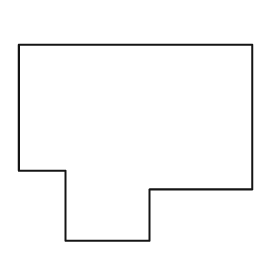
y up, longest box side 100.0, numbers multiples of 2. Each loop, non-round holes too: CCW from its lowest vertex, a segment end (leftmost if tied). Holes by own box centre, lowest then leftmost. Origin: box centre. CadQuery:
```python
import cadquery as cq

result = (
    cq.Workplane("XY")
    .moveTo(-30.0, -42.0)
    .lineTo(6.0, -42.0)
    .lineTo(6.0, -20.0)
    .lineTo(50.0, -20.0)
    .lineTo(50.0, 42.0)
    .lineTo(-50.0, 42.0)
    .lineTo(-50.0, -12.0)
    .lineTo(-30.0, -12.0)
    .close()
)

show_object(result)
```